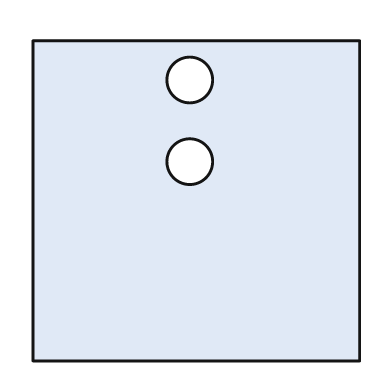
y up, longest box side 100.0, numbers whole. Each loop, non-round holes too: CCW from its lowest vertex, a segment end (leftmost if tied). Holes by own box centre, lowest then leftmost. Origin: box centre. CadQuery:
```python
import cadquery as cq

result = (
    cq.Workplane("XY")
    .moveTo(-50.0, -49.0)
    .lineTo(50.0, -49.0)
    .lineTo(50.0, 49.0)
    .lineTo(-50.0, 49.0)
    .close()
    .moveTo(-2.0, 12.0)
    .circle(7.0)
    .moveTo(-2.0, 37.0)
    .circle(7.0)
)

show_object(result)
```